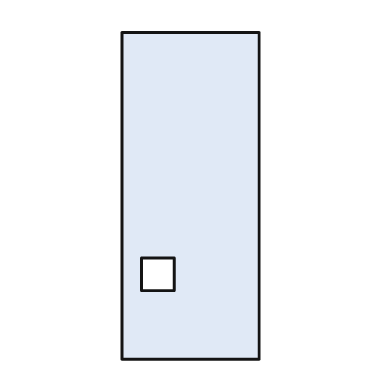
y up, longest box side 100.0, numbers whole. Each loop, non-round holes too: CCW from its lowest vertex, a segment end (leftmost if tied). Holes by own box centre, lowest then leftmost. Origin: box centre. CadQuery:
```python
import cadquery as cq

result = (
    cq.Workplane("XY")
    .moveTo(-21.0, -50.0)
    .lineTo(21.0, -50.0)
    .lineTo(21.0, 50.0)
    .lineTo(-21.0, 50.0)
    .close()
    .moveTo(-15.0, -29.0)
    .lineTo(-5.0, -29.0)
    .lineTo(-5.0, -19.0)
    .lineTo(-15.0, -19.0)
    .close()
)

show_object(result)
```